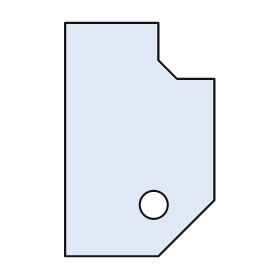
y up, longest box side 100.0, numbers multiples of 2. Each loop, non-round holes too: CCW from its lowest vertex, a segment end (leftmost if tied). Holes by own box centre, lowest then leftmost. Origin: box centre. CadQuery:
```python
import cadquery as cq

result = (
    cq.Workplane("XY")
    .moveTo(-32.0, -50.0)
    .lineTo(8.0, -50.0)
    .lineTo(32.0, -26.0)
    .lineTo(32.0, 26.0)
    .lineTo(16.0, 26.0)
    .lineTo(8.0, 34.0)
    .lineTo(8.0, 50.0)
    .lineTo(-32.0, 50.0)
    .close()
    .moveTo(6.0, -28.0)
    .circle(6.0)
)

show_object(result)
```